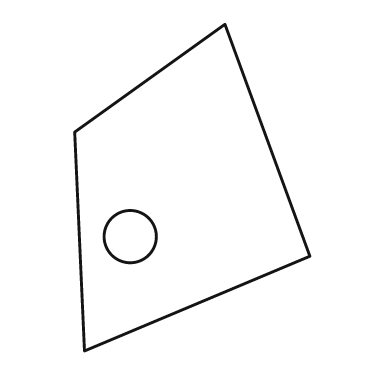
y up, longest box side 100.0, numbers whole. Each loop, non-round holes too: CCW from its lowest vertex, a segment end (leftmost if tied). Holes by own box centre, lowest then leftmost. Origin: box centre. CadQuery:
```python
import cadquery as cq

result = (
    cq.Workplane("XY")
    .moveTo(-33.0, -50.0)
    .lineTo(36.0, -21.0)
    .lineTo(10.0, 50.0)
    .lineTo(-36.0, 17.0)
    .close()
    .moveTo(-19.0, -15.0)
    .circle(8.0)
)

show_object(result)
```